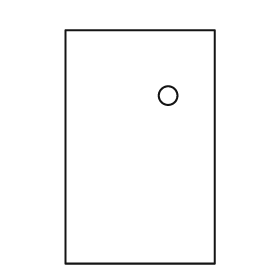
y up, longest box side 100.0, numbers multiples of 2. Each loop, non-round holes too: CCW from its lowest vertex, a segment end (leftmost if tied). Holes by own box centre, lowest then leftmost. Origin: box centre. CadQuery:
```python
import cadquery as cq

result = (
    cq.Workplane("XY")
    .moveTo(-32.0, -50.0)
    .lineTo(32.0, -50.0)
    .lineTo(32.0, 50.0)
    .lineTo(-32.0, 50.0)
    .close()
    .moveTo(12.0, 22.0)
    .circle(4.0)
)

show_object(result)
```